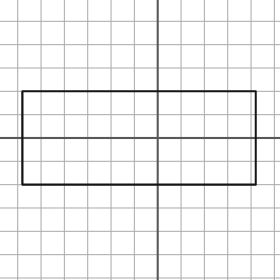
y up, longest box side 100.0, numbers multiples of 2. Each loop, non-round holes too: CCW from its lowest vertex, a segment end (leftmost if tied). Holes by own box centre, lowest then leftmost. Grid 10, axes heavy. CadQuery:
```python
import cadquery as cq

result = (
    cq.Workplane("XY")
    .moveTo(-58.0, -20.0)
    .lineTo(42.0, -20.0)
    .lineTo(42.0, 20.0)
    .lineTo(-58.0, 20.0)
    .close()
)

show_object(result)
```